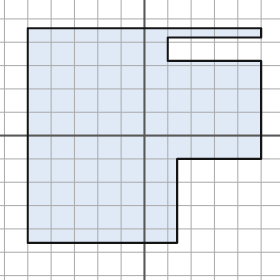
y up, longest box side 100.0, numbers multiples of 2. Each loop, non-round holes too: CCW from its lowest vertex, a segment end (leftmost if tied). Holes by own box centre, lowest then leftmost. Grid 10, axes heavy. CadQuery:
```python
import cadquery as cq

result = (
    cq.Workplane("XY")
    .moveTo(-50.0, -46.0)
    .lineTo(14.0, -46.0)
    .lineTo(14.0, -10.0)
    .lineTo(50.0, -10.0)
    .lineTo(50.0, 32.0)
    .lineTo(10.0, 32.0)
    .lineTo(10.0, 42.0)
    .lineTo(50.0, 42.0)
    .lineTo(50.0, 46.0)
    .lineTo(-50.0, 46.0)
    .close()
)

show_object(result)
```